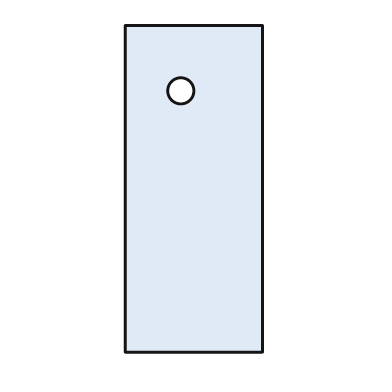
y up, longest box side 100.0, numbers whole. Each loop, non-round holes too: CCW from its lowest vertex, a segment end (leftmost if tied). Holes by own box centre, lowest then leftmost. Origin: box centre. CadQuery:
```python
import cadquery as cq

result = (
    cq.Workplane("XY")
    .moveTo(-21.0, -50.0)
    .lineTo(21.0, -50.0)
    .lineTo(21.0, 50.0)
    .lineTo(-21.0, 50.0)
    .close()
    .moveTo(-4.0, 30.0)
    .circle(4.0)
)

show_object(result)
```